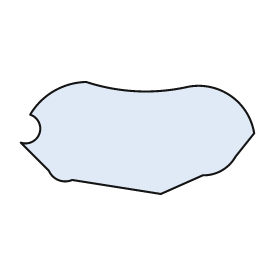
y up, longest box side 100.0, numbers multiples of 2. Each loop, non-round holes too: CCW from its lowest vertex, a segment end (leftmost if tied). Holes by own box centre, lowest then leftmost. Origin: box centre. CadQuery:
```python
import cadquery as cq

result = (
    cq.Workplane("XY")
    .moveTo(10.0, -24.0)
    .lineTo(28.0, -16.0)
    .threePointArc((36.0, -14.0), (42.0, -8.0))
    .lineTo(50.0, 2.0)
    .threePointArc((40.0, 18.0), (22.0, 22.0))
    .threePointArc((0.0, 20.0), (-22.0, 24.0))
    .threePointArc((-36.0, 20.0), (-46.0, 10.0))
    .threePointArc((-42.0, 2.0), (-50.0, -2.0))
    .lineTo(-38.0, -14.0)
    .threePointArc((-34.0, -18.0), (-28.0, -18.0))
    .close()
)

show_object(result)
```